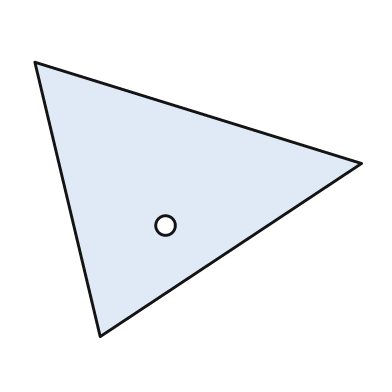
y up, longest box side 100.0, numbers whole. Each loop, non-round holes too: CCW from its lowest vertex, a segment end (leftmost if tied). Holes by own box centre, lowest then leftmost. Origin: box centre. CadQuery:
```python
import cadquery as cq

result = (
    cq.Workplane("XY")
    .moveTo(-30.0, -42.0)
    .lineTo(50.0, 11.0)
    .lineTo(-50.0, 42.0)
    .close()
    .moveTo(-10.0, -8.0)
    .circle(3.0)
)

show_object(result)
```